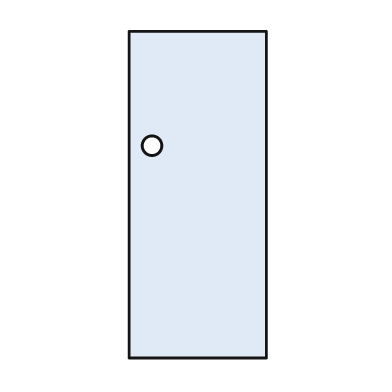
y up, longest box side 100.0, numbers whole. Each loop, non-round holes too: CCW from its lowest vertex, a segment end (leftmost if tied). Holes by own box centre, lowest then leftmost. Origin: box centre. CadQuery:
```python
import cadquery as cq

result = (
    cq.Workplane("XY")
    .moveTo(-21.0, -50.0)
    .lineTo(21.0, -50.0)
    .lineTo(21.0, 50.0)
    .lineTo(-21.0, 50.0)
    .close()
    .moveTo(-14.0, 15.0)
    .circle(3.0)
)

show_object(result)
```